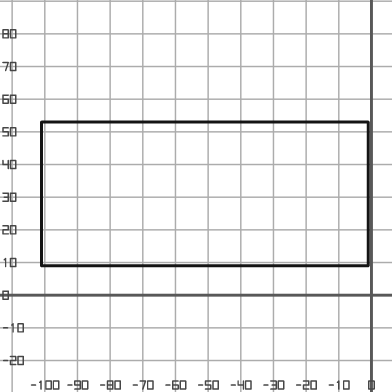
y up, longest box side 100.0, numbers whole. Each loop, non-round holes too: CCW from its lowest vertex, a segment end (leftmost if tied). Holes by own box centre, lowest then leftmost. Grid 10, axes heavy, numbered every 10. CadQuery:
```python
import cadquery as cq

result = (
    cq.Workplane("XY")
    .moveTo(-101.0, 9.0)
    .lineTo(-1.0, 9.0)
    .lineTo(-1.0, 53.0)
    .lineTo(-101.0, 53.0)
    .close()
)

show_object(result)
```